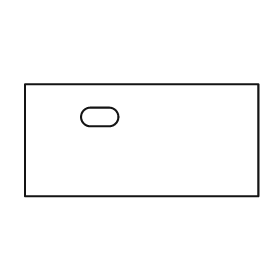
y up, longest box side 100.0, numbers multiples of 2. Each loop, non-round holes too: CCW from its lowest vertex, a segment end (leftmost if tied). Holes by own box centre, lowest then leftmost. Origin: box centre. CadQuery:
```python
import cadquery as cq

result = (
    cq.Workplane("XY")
    .moveTo(-50.0, -24.0)
    .lineTo(50.0, -24.0)
    .lineTo(50.0, 24.0)
    .lineTo(-50.0, 24.0)
    .close()
    .moveTo(-22.0, 6.0)
    .lineTo(-14.0, 6.0)
    .threePointArc((-10.0, 10.0), (-14.0, 14.0))
    .lineTo(-22.0, 14.0)
    .threePointArc((-26.0, 10.0), (-22.0, 6.0))
    .close()
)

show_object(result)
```